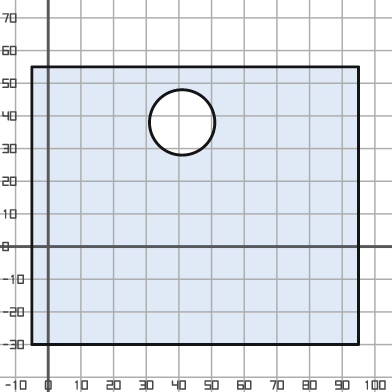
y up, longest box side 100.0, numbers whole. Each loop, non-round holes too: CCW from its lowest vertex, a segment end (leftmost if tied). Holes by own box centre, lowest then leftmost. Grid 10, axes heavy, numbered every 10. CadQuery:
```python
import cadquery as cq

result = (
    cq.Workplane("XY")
    .moveTo(-5.0, -30.0)
    .lineTo(95.0, -30.0)
    .lineTo(95.0, 55.0)
    .lineTo(-5.0, 55.0)
    .close()
    .moveTo(41.0, 38.0)
    .circle(10.0)
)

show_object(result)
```